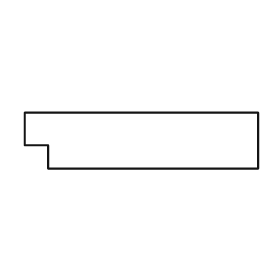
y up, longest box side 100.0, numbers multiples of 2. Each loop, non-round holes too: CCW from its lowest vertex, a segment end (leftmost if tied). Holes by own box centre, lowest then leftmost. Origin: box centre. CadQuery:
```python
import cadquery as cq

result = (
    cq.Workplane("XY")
    .moveTo(-40.0, -12.0)
    .lineTo(50.0, -12.0)
    .lineTo(50.0, 12.0)
    .lineTo(-50.0, 12.0)
    .lineTo(-50.0, -2.0)
    .lineTo(-40.0, -2.0)
    .close()
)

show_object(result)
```